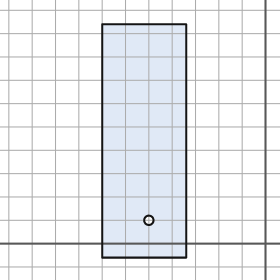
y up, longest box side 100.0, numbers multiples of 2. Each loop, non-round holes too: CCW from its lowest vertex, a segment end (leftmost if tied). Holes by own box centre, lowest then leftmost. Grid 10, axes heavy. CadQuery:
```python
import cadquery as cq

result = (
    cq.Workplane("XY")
    .moveTo(-70.0, -6.0)
    .lineTo(-34.0, -6.0)
    .lineTo(-34.0, 94.0)
    .lineTo(-70.0, 94.0)
    .close()
    .moveTo(-50.0, 10.0)
    .circle(2.0)
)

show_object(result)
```